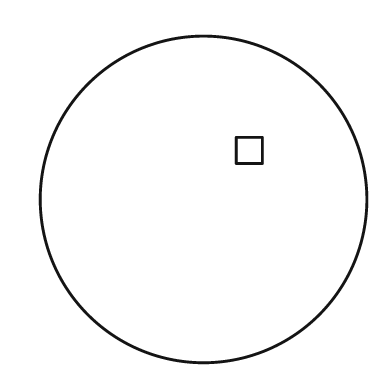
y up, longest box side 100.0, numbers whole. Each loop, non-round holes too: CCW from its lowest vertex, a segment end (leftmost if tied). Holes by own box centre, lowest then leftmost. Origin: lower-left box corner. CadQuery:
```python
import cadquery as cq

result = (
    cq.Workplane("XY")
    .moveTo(50.0, 50.0)
    .circle(50.0)
    .moveTo(60.0, 61.0)
    .lineTo(68.0, 61.0)
    .lineTo(68.0, 69.0)
    .lineTo(60.0, 69.0)
    .close()
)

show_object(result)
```